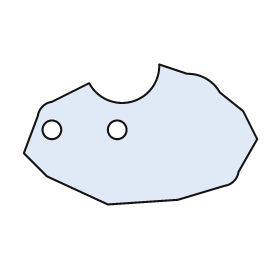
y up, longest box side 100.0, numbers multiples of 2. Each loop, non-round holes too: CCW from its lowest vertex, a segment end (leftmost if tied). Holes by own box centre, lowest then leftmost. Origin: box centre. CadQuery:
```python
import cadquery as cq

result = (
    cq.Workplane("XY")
    .moveTo(-14.0, -30.0)
    .lineTo(16.0, -28.0)
    .lineTo(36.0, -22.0)
    .threePointArc((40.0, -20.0), (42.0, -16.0))
    .lineTo(50.0, -2.0)
    .lineTo(44.0, 10.0)
    .lineTo(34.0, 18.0)
    .threePointArc((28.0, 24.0), (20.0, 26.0))
    .lineTo(8.0, 30.0)
    .threePointArc((-4.0, 14.0), (-22.0, 22.0))
    .lineTo(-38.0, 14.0)
    .threePointArc((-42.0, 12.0), (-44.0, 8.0))
    .lineTo(-50.0, -8.0)
    .lineTo(-40.0, -18.0)
    .close()
    .moveTo(-38.0, 2.0)
    .circle(4.0)
    .moveTo(-10.0, 2.0)
    .circle(4.0)
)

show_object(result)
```